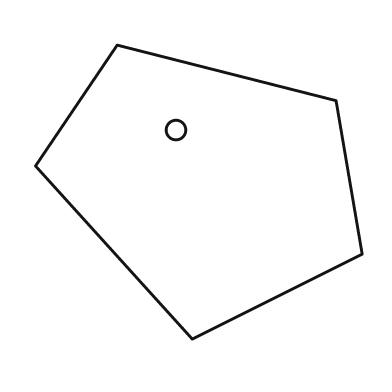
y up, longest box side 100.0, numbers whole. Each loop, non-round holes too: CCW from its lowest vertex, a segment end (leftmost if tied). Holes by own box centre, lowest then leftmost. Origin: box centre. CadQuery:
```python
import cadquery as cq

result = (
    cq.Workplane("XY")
    .moveTo(-2.0, -45.0)
    .lineTo(50.0, -19.0)
    .lineTo(42.0, 28.0)
    .lineTo(-25.0, 45.0)
    .lineTo(-50.0, 8.0)
    .close()
    .moveTo(-7.0, 19.0)
    .circle(3.0)
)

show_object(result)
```